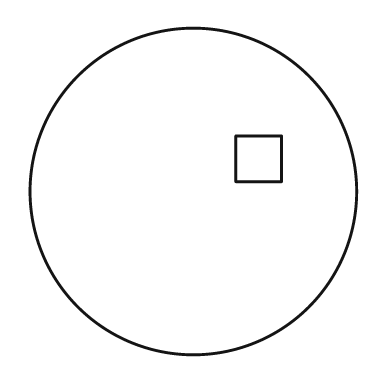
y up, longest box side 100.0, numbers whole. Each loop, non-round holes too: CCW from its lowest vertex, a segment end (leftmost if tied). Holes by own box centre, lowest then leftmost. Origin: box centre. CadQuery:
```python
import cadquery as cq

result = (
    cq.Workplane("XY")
    .moveTo(0.0, 0.0)
    .circle(50.0)
    .moveTo(13.0, 3.0)
    .lineTo(27.0, 3.0)
    .lineTo(27.0, 17.0)
    .lineTo(13.0, 17.0)
    .close()
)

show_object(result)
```